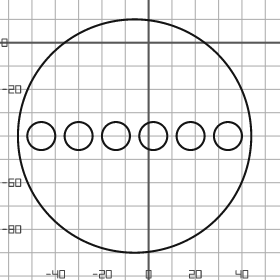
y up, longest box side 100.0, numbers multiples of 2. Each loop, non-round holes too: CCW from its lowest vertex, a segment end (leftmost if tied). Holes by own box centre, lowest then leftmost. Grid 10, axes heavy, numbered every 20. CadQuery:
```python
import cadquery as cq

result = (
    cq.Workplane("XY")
    .moveTo(-6.0, -40.0)
    .circle(50.0)
    .moveTo(-46.0, -40.0)
    .circle(6.0)
    .moveTo(-30.0, -40.0)
    .circle(6.0)
    .moveTo(-14.0, -40.0)
    .circle(6.0)
    .moveTo(2.0, -40.0)
    .circle(6.0)
    .moveTo(18.0, -40.0)
    .circle(6.0)
    .moveTo(34.0, -40.0)
    .circle(6.0)
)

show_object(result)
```